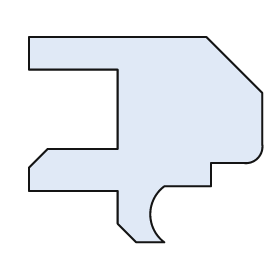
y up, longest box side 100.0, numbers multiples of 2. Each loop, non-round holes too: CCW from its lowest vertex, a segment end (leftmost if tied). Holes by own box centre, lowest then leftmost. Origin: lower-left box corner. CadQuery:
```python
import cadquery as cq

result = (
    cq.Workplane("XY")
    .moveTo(46.0, 0.0)
    .lineTo(58.0, 0.0)
    .threePointArc((52.0, 12.0), (58.0, 24.0))
    .lineTo(78.0, 24.0)
    .lineTo(78.0, 34.0)
    .lineTo(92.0, 34.0)
    .threePointArc((98.0, 36.0), (100.0, 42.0))
    .lineTo(100.0, 64.0)
    .lineTo(76.0, 88.0)
    .lineTo(0.0, 88.0)
    .lineTo(0.0, 74.0)
    .lineTo(38.0, 74.0)
    .lineTo(38.0, 40.0)
    .lineTo(8.0, 40.0)
    .lineTo(0.0, 32.0)
    .lineTo(0.0, 22.0)
    .lineTo(38.0, 22.0)
    .lineTo(38.0, 8.0)
    .close()
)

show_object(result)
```